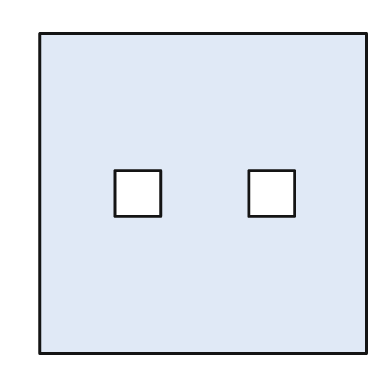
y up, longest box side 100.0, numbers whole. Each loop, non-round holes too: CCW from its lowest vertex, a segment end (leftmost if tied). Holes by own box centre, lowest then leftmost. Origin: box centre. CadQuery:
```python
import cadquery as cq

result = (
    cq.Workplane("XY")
    .moveTo(-50.0, -49.0)
    .lineTo(50.0, -49.0)
    .lineTo(50.0, 49.0)
    .lineTo(-50.0, 49.0)
    .close()
    .moveTo(-27.0, -7.0)
    .lineTo(-13.0, -7.0)
    .lineTo(-13.0, 7.0)
    .lineTo(-27.0, 7.0)
    .close()
    .moveTo(14.0, -7.0)
    .lineTo(28.0, -7.0)
    .lineTo(28.0, 7.0)
    .lineTo(14.0, 7.0)
    .close()
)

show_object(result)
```